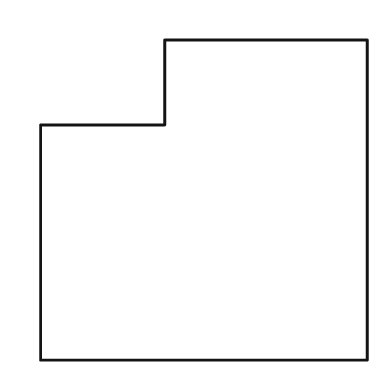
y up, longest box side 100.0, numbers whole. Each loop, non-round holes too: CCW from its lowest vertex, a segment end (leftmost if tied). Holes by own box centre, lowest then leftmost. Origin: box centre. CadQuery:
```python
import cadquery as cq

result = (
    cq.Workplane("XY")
    .moveTo(-50.0, -49.0)
    .lineTo(50.0, -49.0)
    .lineTo(50.0, 49.0)
    .lineTo(-12.0, 49.0)
    .lineTo(-12.0, 23.0)
    .lineTo(-50.0, 23.0)
    .close()
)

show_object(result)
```